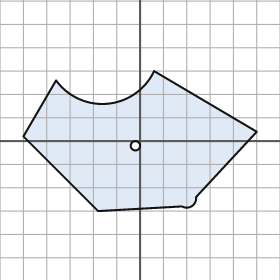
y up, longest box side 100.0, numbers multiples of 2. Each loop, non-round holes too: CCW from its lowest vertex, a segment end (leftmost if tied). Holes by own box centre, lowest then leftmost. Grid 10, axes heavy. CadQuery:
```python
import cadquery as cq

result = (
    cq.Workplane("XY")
    .moveTo(-18.0, -30.0)
    .lineTo(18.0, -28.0)
    .threePointArc((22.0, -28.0), (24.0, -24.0))
    .lineTo(50.0, 4.0)
    .lineTo(6.0, 30.0)
    .threePointArc((-14.0, 16.0), (-36.0, 26.0))
    .lineTo(-50.0, 2.0)
    .close()
    .moveTo(-2.0, -2.0)
    .circle(2.0)
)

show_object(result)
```